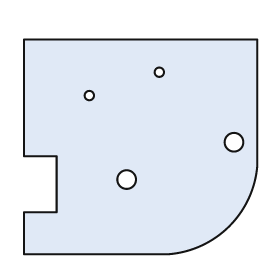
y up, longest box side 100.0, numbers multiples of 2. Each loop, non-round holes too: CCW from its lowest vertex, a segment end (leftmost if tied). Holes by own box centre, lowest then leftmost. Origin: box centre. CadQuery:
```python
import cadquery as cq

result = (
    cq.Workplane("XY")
    .moveTo(-50.0, -46.0)
    .lineTo(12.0, -46.0)
    .threePointArc((38.0, -34.0), (50.0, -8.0))
    .lineTo(50.0, 46.0)
    .lineTo(-50.0, 46.0)
    .lineTo(-50.0, -4.0)
    .lineTo(-36.0, -4.0)
    .lineTo(-36.0, -28.0)
    .lineTo(-50.0, -28.0)
    .close()
    .moveTo(-6.0, -14.0)
    .circle(4.0)
    .moveTo(40.0, 2.0)
    .circle(4.0)
    .moveTo(-22.0, 22.0)
    .circle(2.0)
    .moveTo(8.0, 32.0)
    .circle(2.0)
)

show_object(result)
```